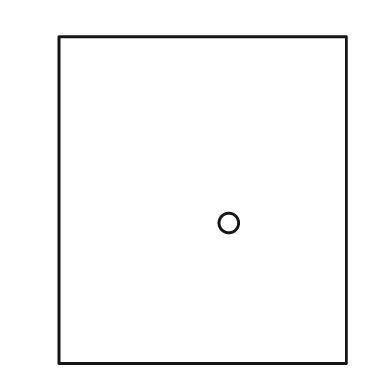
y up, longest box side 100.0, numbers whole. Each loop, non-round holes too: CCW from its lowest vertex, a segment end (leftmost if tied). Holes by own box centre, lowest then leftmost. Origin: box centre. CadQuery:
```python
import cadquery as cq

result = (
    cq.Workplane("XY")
    .moveTo(-44.0, -50.0)
    .lineTo(44.0, -50.0)
    .lineTo(44.0, 50.0)
    .lineTo(-44.0, 50.0)
    .close()
    .moveTo(8.0, -7.0)
    .circle(3.0)
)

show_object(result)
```